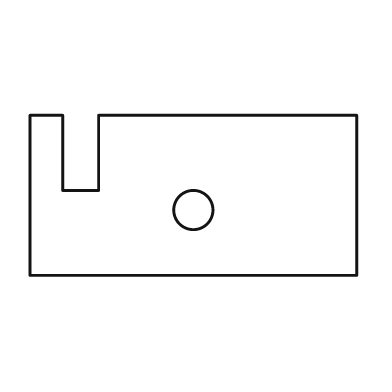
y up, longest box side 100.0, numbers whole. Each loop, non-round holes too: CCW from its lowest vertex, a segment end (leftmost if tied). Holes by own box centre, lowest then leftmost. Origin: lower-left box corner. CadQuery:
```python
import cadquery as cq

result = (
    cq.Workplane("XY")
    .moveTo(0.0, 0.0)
    .lineTo(100.0, 0.0)
    .lineTo(100.0, 49.0)
    .lineTo(21.0, 49.0)
    .lineTo(21.0, 26.0)
    .lineTo(10.0, 26.0)
    .lineTo(10.0, 49.0)
    .lineTo(0.0, 49.0)
    .close()
    .moveTo(50.0, 20.0)
    .circle(6.0)
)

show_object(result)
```